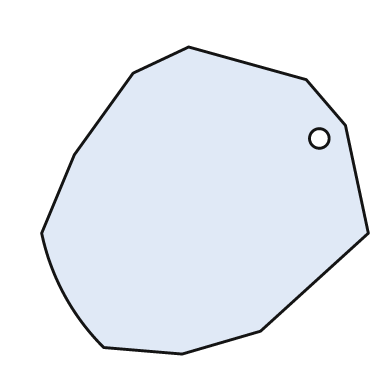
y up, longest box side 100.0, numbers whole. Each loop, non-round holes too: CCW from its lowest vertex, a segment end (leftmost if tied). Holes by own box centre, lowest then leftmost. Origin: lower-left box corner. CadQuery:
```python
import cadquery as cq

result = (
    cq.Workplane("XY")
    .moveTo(43.0, 0.0)
    .lineTo(67.0, 7.0)
    .lineTo(100.0, 37.0)
    .lineTo(93.0, 70.0)
    .lineTo(81.0, 84.0)
    .lineTo(45.0, 94.0)
    .lineTo(28.0, 86.0)
    .lineTo(10.0, 61.0)
    .lineTo(0.0, 37.0)
    .threePointArc((7.0, 18.0), (19.0, 2.0))
    .close()
    .moveTo(85.0, 66.0)
    .circle(3.0)
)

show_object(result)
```